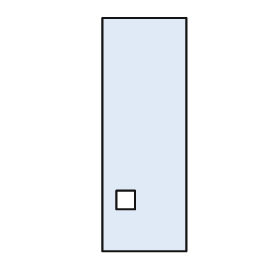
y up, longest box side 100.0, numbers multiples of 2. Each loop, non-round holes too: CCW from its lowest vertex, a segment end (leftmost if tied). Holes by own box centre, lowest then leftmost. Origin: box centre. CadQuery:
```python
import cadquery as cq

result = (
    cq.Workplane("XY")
    .moveTo(-18.0, -50.0)
    .lineTo(18.0, -50.0)
    .lineTo(18.0, 50.0)
    .lineTo(-18.0, 50.0)
    .close()
    .moveTo(-12.0, -32.0)
    .lineTo(-4.0, -32.0)
    .lineTo(-4.0, -24.0)
    .lineTo(-12.0, -24.0)
    .close()
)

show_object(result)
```